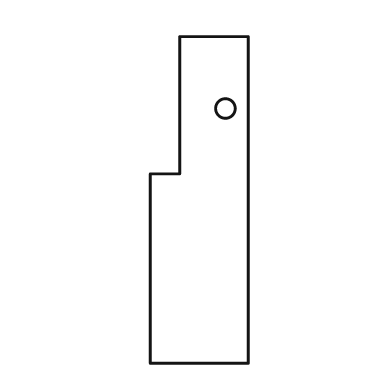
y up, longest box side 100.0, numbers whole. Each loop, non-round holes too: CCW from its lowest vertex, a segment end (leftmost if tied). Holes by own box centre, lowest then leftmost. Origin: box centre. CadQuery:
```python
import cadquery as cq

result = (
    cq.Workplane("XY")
    .moveTo(-15.0, -50.0)
    .lineTo(15.0, -50.0)
    .lineTo(15.0, 50.0)
    .lineTo(-6.0, 50.0)
    .lineTo(-6.0, 8.0)
    .lineTo(-15.0, 8.0)
    .close()
    .moveTo(8.0, 28.0)
    .circle(3.0)
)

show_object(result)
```